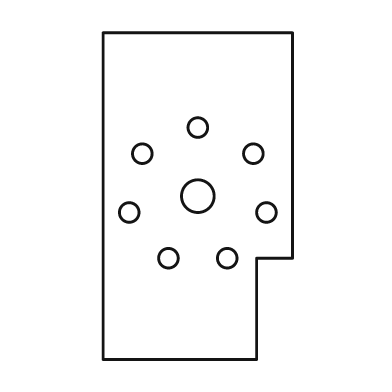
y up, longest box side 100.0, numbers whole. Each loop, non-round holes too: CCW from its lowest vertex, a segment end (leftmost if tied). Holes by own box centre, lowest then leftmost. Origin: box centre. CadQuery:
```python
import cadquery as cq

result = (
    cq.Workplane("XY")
    .moveTo(-29.0, -50.0)
    .lineTo(18.0, -50.0)
    .lineTo(18.0, -19.0)
    .lineTo(29.0, -19.0)
    .lineTo(29.0, 50.0)
    .lineTo(-29.0, 50.0)
    .close()
    .moveTo(-9.0, -19.0)
    .circle(3.0)
    .moveTo(9.0, -19.0)
    .circle(3.0)
    .moveTo(-21.0, -5.0)
    .circle(3.0)
    .moveTo(21.0, -5.0)
    .circle(3.0)
    .moveTo(0.0, 0.0)
    .circle(5.0)
    .moveTo(-17.0, 13.0)
    .circle(3.0)
    .moveTo(17.0, 13.0)
    .circle(3.0)
    .moveTo(0.0, 21.0)
    .circle(3.0)
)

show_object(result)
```